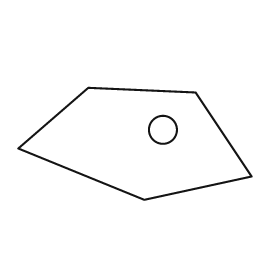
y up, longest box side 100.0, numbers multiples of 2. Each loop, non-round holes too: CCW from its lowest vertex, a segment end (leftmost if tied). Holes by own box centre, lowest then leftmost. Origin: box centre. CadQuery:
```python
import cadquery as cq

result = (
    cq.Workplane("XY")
    .moveTo(4.0, -24.0)
    .lineTo(50.0, -14.0)
    .lineTo(26.0, 22.0)
    .lineTo(-20.0, 24.0)
    .lineTo(-50.0, -2.0)
    .close()
    .moveTo(12.0, 6.0)
    .circle(6.0)
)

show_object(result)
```